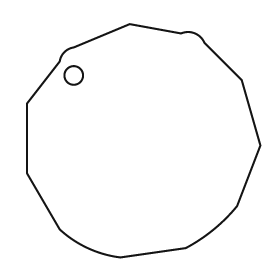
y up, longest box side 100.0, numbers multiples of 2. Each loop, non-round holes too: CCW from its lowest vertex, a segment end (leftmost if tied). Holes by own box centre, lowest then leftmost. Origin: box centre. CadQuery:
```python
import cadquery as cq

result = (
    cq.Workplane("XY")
    .moveTo(-10.0, -50.0)
    .lineTo(18.0, -46.0)
    .threePointArc((30.0, -38.0), (40.0, -28.0))
    .lineTo(50.0, -2.0)
    .lineTo(42.0, 26.0)
    .lineTo(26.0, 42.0)
    .threePointArc((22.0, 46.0), (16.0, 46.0))
    .lineTo(-6.0, 50.0)
    .lineTo(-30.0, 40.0)
    .threePointArc((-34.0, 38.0), (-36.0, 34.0))
    .lineTo(-50.0, 16.0)
    .lineTo(-50.0, -14.0)
    .lineTo(-36.0, -38.0)
    .threePointArc((-24.0, -46.0), (-10.0, -50.0))
    .close()
    .moveTo(-30.0, 28.0)
    .circle(4.0)
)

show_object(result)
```